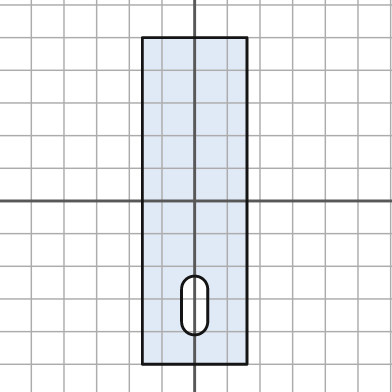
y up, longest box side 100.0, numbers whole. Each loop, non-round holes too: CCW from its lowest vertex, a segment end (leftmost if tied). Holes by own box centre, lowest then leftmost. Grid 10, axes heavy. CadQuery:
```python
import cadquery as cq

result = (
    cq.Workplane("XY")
    .moveTo(-16.0, -50.0)
    .lineTo(16.0, -50.0)
    .lineTo(16.0, 50.0)
    .lineTo(-16.0, 50.0)
    .close()
    .moveTo(-4.0, -37.0)
    .threePointArc((0.0, -41.0), (4.0, -37.0))
    .lineTo(4.0, -27.0)
    .threePointArc((0.0, -23.0), (-4.0, -27.0))
    .close()
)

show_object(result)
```